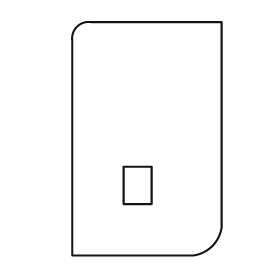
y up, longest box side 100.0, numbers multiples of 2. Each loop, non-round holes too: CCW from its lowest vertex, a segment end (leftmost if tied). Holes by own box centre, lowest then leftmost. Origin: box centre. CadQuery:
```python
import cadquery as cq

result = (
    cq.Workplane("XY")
    .moveTo(-32.0, -50.0)
    .lineTo(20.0, -50.0)
    .threePointArc((28.0, -46.0), (32.0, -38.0))
    .lineTo(32.0, 50.0)
    .lineTo(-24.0, 50.0)
    .threePointArc((-30.0, 48.0), (-32.0, 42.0))
    .close()
    .moveTo(-10.0, -28.0)
    .lineTo(2.0, -28.0)
    .lineTo(2.0, -12.0)
    .lineTo(-10.0, -12.0)
    .close()
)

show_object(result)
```